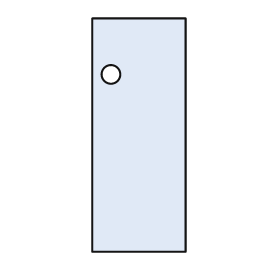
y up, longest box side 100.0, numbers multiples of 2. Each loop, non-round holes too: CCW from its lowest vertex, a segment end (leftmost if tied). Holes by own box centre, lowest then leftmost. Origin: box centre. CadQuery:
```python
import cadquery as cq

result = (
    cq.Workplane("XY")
    .moveTo(-20.0, -50.0)
    .lineTo(20.0, -50.0)
    .lineTo(20.0, 50.0)
    .lineTo(-20.0, 50.0)
    .close()
    .moveTo(-12.0, 26.0)
    .circle(4.0)
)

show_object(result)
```